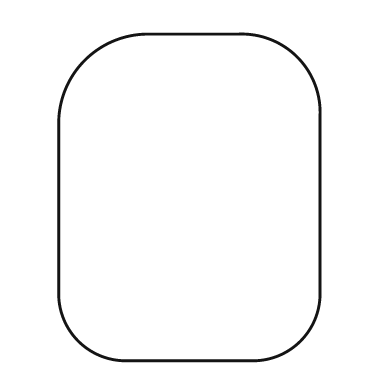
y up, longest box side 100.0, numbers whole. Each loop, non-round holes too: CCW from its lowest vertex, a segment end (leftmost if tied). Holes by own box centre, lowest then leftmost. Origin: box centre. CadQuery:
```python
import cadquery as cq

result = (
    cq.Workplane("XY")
    .moveTo(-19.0, -50.0)
    .lineTo(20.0, -50.0)
    .threePointArc((34.0, -44.0), (40.0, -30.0))
    .lineTo(40.0, 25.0)
    .threePointArc((33.0, 43.0), (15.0, 50.0))
    .lineTo(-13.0, 50.0)
    .threePointArc((-32.0, 42.0), (-40.0, 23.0))
    .lineTo(-40.0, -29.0)
    .threePointArc((-34.0, -44.0), (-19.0, -50.0))
    .close()
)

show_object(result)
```